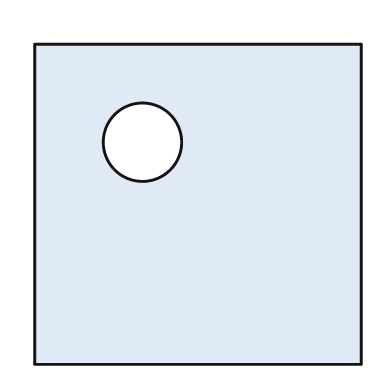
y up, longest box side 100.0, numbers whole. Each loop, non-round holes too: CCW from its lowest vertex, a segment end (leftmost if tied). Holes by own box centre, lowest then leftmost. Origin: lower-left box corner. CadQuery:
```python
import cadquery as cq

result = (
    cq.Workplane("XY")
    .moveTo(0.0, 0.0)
    .lineTo(100.0, 0.0)
    .lineTo(100.0, 98.0)
    .lineTo(0.0, 98.0)
    .close()
    .moveTo(33.0, 68.0)
    .circle(12.0)
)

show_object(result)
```